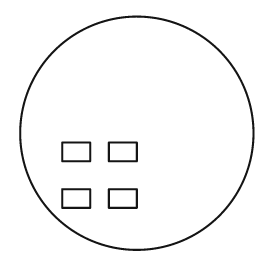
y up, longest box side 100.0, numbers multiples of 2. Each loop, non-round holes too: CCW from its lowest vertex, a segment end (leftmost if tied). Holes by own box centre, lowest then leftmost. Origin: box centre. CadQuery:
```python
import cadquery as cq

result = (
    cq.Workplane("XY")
    .moveTo(0.0, 0.0)
    .circle(50.0)
    .moveTo(-32.0, -32.0)
    .lineTo(-20.0, -32.0)
    .lineTo(-20.0, -24.0)
    .lineTo(-32.0, -24.0)
    .close()
    .moveTo(-12.0, -32.0)
    .lineTo(0.0, -32.0)
    .lineTo(0.0, -24.0)
    .lineTo(-12.0, -24.0)
    .close()
    .moveTo(-32.0, -12.0)
    .lineTo(-20.0, -12.0)
    .lineTo(-20.0, -4.0)
    .lineTo(-32.0, -4.0)
    .close()
    .moveTo(-12.0, -12.0)
    .lineTo(0.0, -12.0)
    .lineTo(0.0, -4.0)
    .lineTo(-12.0, -4.0)
    .close()
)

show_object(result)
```